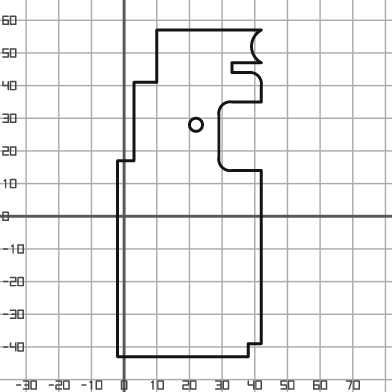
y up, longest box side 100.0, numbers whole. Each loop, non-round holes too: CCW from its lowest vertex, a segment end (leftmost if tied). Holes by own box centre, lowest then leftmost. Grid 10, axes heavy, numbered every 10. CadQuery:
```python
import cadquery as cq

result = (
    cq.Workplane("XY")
    .moveTo(-2.0, -43.0)
    .lineTo(38.0, -43.0)
    .lineTo(38.0, -39.0)
    .lineTo(42.0, -39.0)
    .lineTo(42.0, 14.0)
    .lineTo(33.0, 14.0)
    .threePointArc((30.0, 15.0), (29.0, 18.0))
    .lineTo(29.0, 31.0)
    .threePointArc((30.0, 34.0), (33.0, 35.0))
    .lineTo(42.0, 35.0)
    .lineTo(42.0, 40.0)
    .threePointArc((41.0, 43.0), (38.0, 44.0))
    .lineTo(33.0, 44.0)
    .lineTo(33.0, 47.0)
    .lineTo(42.0, 47.0)
    .threePointArc((39.0, 52.0), (42.0, 57.0))
    .lineTo(10.0, 57.0)
    .lineTo(10.0, 41.0)
    .lineTo(3.0, 41.0)
    .lineTo(3.0, 17.0)
    .lineTo(-2.0, 17.0)
    .close()
    .moveTo(22.0, 28.0)
    .circle(2.0)
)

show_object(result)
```